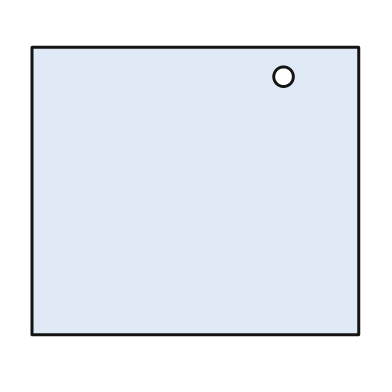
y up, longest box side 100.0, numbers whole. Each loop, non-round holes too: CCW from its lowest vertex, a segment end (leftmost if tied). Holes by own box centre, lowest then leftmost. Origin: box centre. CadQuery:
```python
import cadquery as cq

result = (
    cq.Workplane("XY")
    .moveTo(-50.0, -44.0)
    .lineTo(50.0, -44.0)
    .lineTo(50.0, 44.0)
    .lineTo(-50.0, 44.0)
    .close()
    .moveTo(27.0, 35.0)
    .circle(3.0)
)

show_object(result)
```